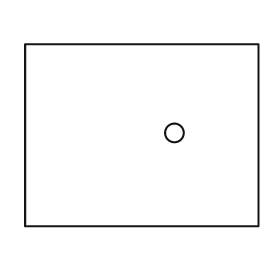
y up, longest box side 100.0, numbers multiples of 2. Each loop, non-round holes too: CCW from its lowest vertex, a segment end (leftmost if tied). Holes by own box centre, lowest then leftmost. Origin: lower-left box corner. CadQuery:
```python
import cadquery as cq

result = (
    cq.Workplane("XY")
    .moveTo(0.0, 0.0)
    .lineTo(100.0, 0.0)
    .lineTo(100.0, 78.0)
    .lineTo(0.0, 78.0)
    .close()
    .moveTo(64.0, 40.0)
    .circle(4.0)
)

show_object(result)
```